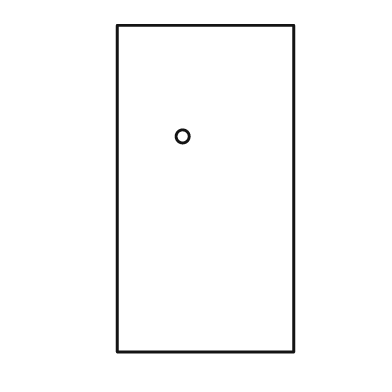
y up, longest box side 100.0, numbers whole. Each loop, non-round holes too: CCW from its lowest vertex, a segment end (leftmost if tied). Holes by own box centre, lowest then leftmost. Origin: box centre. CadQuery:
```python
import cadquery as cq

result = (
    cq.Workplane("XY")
    .moveTo(-27.0, -50.0)
    .lineTo(27.0, -50.0)
    .lineTo(27.0, 50.0)
    .lineTo(-27.0, 50.0)
    .close()
    .moveTo(-7.0, 16.0)
    .circle(2.0)
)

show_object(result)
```